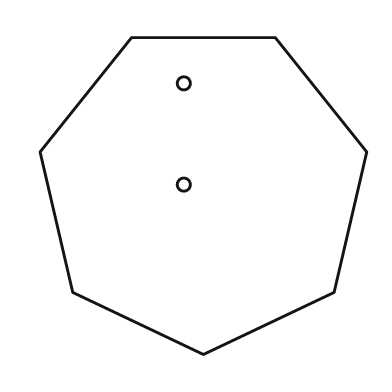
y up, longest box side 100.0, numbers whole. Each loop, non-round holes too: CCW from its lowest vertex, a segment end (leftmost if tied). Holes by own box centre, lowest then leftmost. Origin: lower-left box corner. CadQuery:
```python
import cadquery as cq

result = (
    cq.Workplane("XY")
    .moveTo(50.0, 0.0)
    .lineTo(90.0, 19.0)
    .lineTo(100.0, 62.0)
    .lineTo(72.0, 97.0)
    .lineTo(28.0, 97.0)
    .lineTo(0.0, 62.0)
    .lineTo(10.0, 19.0)
    .close()
    .moveTo(44.0, 52.0)
    .circle(2.0)
    .moveTo(44.0, 83.0)
    .circle(2.0)
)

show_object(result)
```